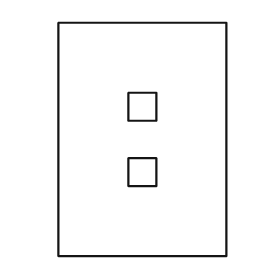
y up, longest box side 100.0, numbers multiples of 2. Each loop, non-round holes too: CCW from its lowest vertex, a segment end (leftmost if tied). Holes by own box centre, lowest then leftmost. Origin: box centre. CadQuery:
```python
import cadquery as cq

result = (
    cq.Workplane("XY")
    .moveTo(-36.0, -50.0)
    .lineTo(36.0, -50.0)
    .lineTo(36.0, 50.0)
    .lineTo(-36.0, 50.0)
    .close()
    .moveTo(-6.0, -20.0)
    .lineTo(6.0, -20.0)
    .lineTo(6.0, -8.0)
    .lineTo(-6.0, -8.0)
    .close()
    .moveTo(-6.0, 8.0)
    .lineTo(6.0, 8.0)
    .lineTo(6.0, 20.0)
    .lineTo(-6.0, 20.0)
    .close()
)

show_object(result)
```